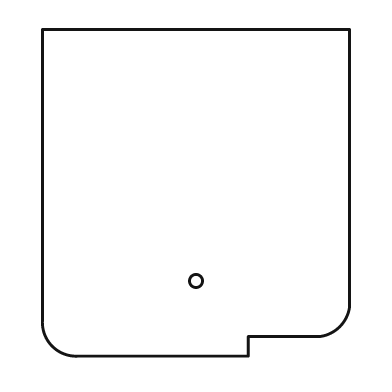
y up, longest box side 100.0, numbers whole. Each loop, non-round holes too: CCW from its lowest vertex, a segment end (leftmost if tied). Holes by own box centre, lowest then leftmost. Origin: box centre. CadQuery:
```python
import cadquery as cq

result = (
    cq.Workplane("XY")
    .moveTo(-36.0, -50.0)
    .lineTo(16.0, -50.0)
    .lineTo(16.0, -44.0)
    .lineTo(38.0, -44.0)
    .threePointArc((44.0, -41.0), (47.0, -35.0))
    .lineTo(47.0, 50.0)
    .lineTo(-47.0, 50.0)
    .lineTo(-47.0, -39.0)
    .threePointArc((-44.0, -47.0), (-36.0, -50.0))
    .close()
    .moveTo(0.0, -27.0)
    .circle(2.0)
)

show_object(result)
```